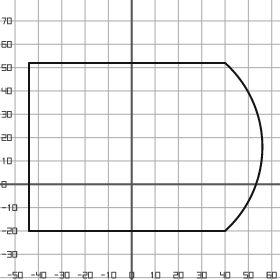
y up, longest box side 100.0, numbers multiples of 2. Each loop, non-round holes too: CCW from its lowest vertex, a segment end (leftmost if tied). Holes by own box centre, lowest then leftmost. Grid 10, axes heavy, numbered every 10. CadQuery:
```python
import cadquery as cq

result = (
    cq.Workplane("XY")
    .moveTo(-44.0, -20.0)
    .lineTo(40.0, -20.0)
    .threePointArc((56.0, 16.0), (40.0, 52.0))
    .lineTo(-44.0, 52.0)
    .close()
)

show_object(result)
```